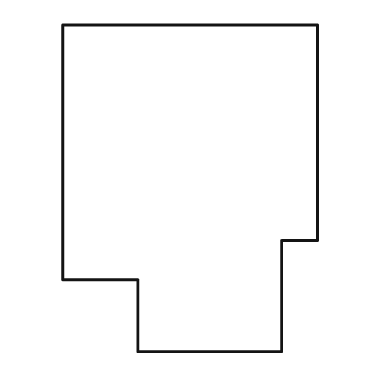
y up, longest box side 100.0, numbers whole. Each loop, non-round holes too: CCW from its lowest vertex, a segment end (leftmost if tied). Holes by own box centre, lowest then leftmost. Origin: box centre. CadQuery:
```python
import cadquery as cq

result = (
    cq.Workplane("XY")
    .moveTo(-16.0, -50.0)
    .lineTo(28.0, -50.0)
    .lineTo(28.0, -16.0)
    .lineTo(39.0, -16.0)
    .lineTo(39.0, 50.0)
    .lineTo(-39.0, 50.0)
    .lineTo(-39.0, -28.0)
    .lineTo(-16.0, -28.0)
    .close()
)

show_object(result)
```